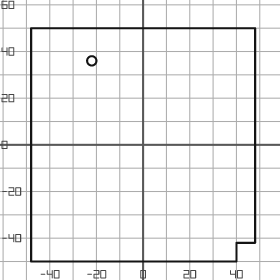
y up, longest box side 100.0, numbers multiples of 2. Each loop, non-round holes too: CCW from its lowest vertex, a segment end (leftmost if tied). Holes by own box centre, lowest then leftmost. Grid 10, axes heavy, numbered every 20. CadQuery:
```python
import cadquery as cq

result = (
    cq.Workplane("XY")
    .moveTo(-48.0, -50.0)
    .lineTo(40.0, -50.0)
    .lineTo(40.0, -42.0)
    .lineTo(48.0, -42.0)
    .lineTo(48.0, 50.0)
    .lineTo(-48.0, 50.0)
    .close()
    .moveTo(-22.0, 36.0)
    .circle(2.0)
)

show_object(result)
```